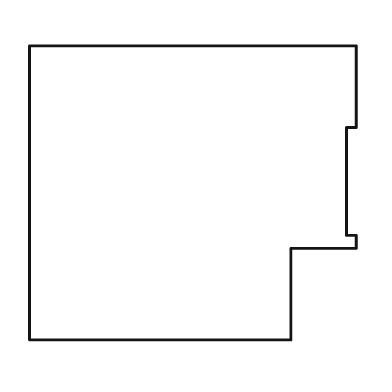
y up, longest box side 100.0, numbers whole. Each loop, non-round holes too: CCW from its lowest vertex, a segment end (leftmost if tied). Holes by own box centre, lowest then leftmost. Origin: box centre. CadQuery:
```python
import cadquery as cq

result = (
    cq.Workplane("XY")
    .moveTo(-50.0, -45.0)
    .lineTo(30.0, -45.0)
    .lineTo(30.0, -17.0)
    .lineTo(50.0, -17.0)
    .lineTo(50.0, -13.0)
    .lineTo(47.0, -13.0)
    .lineTo(47.0, 20.0)
    .lineTo(50.0, 20.0)
    .lineTo(50.0, 45.0)
    .lineTo(-50.0, 45.0)
    .close()
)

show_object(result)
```